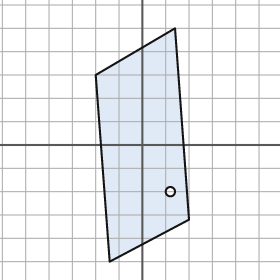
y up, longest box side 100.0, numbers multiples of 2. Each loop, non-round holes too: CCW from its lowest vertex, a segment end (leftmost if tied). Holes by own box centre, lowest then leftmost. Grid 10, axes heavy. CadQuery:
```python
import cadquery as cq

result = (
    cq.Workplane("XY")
    .moveTo(-14.0, -50.0)
    .lineTo(20.0, -32.0)
    .lineTo(14.0, 50.0)
    .lineTo(-20.0, 30.0)
    .close()
    .moveTo(12.0, -20.0)
    .circle(2.0)
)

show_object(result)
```